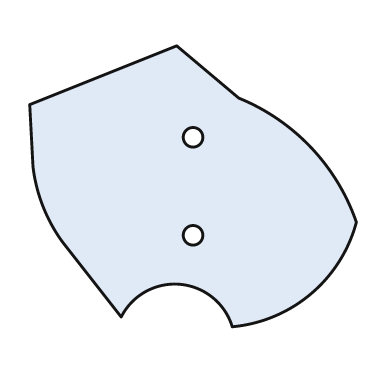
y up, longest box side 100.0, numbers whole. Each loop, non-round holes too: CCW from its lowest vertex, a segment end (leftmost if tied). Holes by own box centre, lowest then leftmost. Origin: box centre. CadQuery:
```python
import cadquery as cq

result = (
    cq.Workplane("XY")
    .moveTo(12.0, -43.0)
    .threePointArc((36.0, -33.0), (50.0, -11.0))
    .threePointArc((36.0, 12.0), (14.0, 27.0))
    .lineTo(-5.0, 43.0)
    .lineTo(-50.0, 25.0)
    .lineTo(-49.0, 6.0)
    .threePointArc((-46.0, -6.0), (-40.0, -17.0))
    .lineTo(-22.0, -40.0)
    .threePointArc((-4.0, -30.0), (12.0, -43.0))
    .close()
    .moveTo(0.0, -15.0)
    .circle(3.0)
    .moveTo(0.0, 15.0)
    .circle(3.0)
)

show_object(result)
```